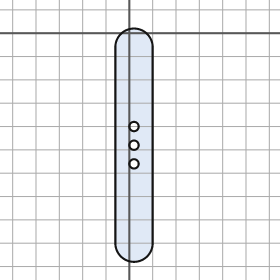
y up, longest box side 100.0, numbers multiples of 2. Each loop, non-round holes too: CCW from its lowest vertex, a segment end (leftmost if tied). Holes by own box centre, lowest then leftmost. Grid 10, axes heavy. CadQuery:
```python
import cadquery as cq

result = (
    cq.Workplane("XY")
    .moveTo(-6.0, -90.0)
    .threePointArc((2.0, -98.0), (10.0, -90.0))
    .lineTo(10.0, -6.0)
    .threePointArc((2.0, 2.0), (-6.0, -6.0))
    .close()
    .moveTo(2.0, -56.0)
    .circle(2.0)
    .moveTo(2.0, -48.0)
    .circle(2.0)
    .moveTo(2.0, -40.0)
    .circle(2.0)
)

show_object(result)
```